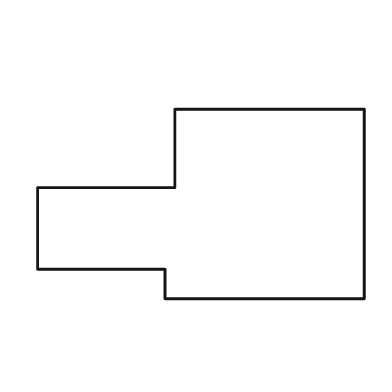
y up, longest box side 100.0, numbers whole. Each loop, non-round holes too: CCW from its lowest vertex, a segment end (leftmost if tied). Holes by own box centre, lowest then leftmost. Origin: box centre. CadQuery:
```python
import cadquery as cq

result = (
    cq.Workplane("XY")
    .moveTo(-11.0, -29.0)
    .lineTo(50.0, -29.0)
    .lineTo(50.0, 29.0)
    .lineTo(-8.0, 29.0)
    .lineTo(-8.0, 5.0)
    .lineTo(-50.0, 5.0)
    .lineTo(-50.0, -20.0)
    .lineTo(-11.0, -20.0)
    .close()
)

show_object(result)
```